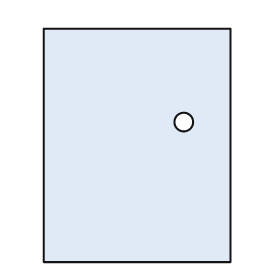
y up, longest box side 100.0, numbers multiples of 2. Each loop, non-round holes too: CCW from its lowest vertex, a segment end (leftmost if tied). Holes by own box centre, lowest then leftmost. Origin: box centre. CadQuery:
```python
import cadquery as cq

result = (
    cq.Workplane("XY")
    .moveTo(-40.0, -50.0)
    .lineTo(40.0, -50.0)
    .lineTo(40.0, 50.0)
    .lineTo(-40.0, 50.0)
    .close()
    .moveTo(20.0, 10.0)
    .circle(4.0)
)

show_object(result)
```